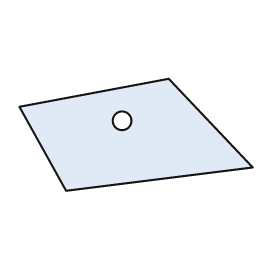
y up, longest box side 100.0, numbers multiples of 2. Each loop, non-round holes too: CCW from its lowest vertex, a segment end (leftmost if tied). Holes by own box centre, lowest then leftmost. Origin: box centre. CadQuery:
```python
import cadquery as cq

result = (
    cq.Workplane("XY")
    .moveTo(-30.0, -24.0)
    .lineTo(50.0, -14.0)
    .lineTo(14.0, 24.0)
    .lineTo(-50.0, 12.0)
    .close()
    .moveTo(-6.0, 6.0)
    .circle(4.0)
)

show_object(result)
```